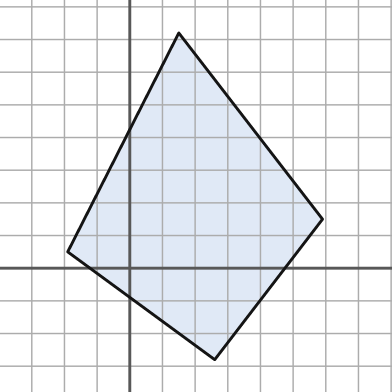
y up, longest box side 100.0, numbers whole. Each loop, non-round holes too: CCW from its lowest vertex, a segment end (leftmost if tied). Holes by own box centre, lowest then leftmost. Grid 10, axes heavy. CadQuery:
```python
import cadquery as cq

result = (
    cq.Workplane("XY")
    .moveTo(26.0, -28.0)
    .lineTo(59.0, 15.0)
    .lineTo(15.0, 72.0)
    .lineTo(-19.0, 5.0)
    .close()
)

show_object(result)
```